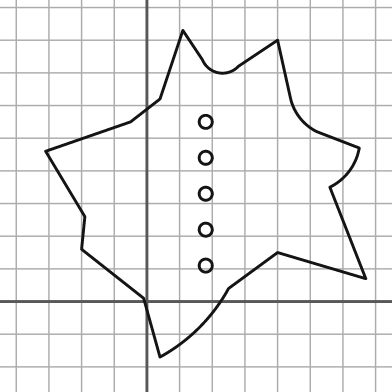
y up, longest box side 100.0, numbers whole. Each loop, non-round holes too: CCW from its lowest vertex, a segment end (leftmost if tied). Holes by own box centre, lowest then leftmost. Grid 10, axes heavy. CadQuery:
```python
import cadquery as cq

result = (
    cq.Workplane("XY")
    .moveTo(4.0, -17.0)
    .threePointArc((16.0, -8.0), (25.0, 4.0))
    .lineTo(40.0, 15.0)
    .lineTo(67.0, 7.0)
    .lineTo(56.0, 35.0)
    .threePointArc((62.0, 40.0), (65.0, 47.0))
    .lineTo(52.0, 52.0)
    .threePointArc((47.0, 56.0), (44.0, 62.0))
    .lineTo(40.0, 80.0)
    .lineTo(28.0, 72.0)
    .threePointArc((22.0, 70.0), (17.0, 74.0))
    .lineTo(11.0, 83.0)
    .lineTo(4.0, 62.0)
    .lineTo(-5.0, 55.0)
    .lineTo(-31.0, 46.0)
    .lineTo(-19.0, 26.0)
    .lineTo(-20.0, 16.0)
    .lineTo(-1.0, 1.0)
    .close()
    .moveTo(18.0, 11.0)
    .circle(2.0)
    .moveTo(18.0, 22.0)
    .circle(2.0)
    .moveTo(18.0, 33.0)
    .circle(2.0)
    .moveTo(18.0, 44.0)
    .circle(2.0)
    .moveTo(18.0, 55.0)
    .circle(2.0)
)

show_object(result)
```